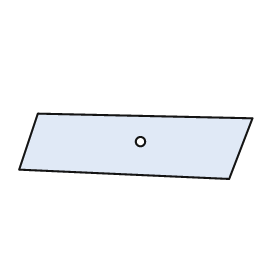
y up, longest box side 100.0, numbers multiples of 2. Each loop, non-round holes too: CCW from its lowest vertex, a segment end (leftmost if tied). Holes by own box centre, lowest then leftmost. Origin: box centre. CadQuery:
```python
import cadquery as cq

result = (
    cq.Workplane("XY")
    .moveTo(40.0, -14.0)
    .lineTo(50.0, 12.0)
    .lineTo(-42.0, 14.0)
    .lineTo(-50.0, -10.0)
    .close()
    .moveTo(2.0, 2.0)
    .circle(2.0)
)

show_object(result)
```